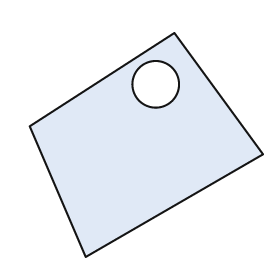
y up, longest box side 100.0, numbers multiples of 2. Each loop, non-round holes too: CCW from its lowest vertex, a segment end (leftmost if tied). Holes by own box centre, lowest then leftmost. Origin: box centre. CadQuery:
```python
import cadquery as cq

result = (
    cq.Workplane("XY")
    .moveTo(-26.0, -48.0)
    .lineTo(50.0, -4.0)
    .lineTo(12.0, 48.0)
    .lineTo(-50.0, 8.0)
    .close()
    .moveTo(4.0, 26.0)
    .circle(10.0)
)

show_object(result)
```